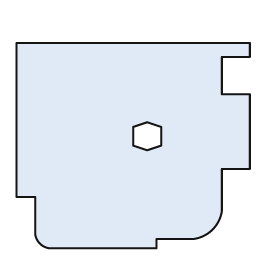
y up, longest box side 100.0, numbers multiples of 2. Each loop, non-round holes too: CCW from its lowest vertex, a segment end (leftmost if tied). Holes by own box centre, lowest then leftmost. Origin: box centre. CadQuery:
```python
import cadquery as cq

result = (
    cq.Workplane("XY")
    .moveTo(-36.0, -44.0)
    .lineTo(10.0, -44.0)
    .lineTo(10.0, -40.0)
    .lineTo(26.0, -40.0)
    .threePointArc((34.0, -36.0), (38.0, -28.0))
    .lineTo(38.0, -10.0)
    .lineTo(50.0, -10.0)
    .lineTo(50.0, 22.0)
    .lineTo(38.0, 22.0)
    .lineTo(38.0, 38.0)
    .lineTo(50.0, 38.0)
    .lineTo(50.0, 44.0)
    .lineTo(-50.0, 44.0)
    .lineTo(-50.0, -22.0)
    .lineTo(-42.0, -22.0)
    .lineTo(-42.0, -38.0)
    .threePointArc((-40.0, -42.0), (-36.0, -44.0))
    .close()
    .moveTo(6.0, -2.0)
    .lineTo(12.0, 0.0)
    .lineTo(12.0, 8.0)
    .lineTo(6.0, 10.0)
    .lineTo(0.0, 8.0)
    .lineTo(0.0, 0.0)
    .close()
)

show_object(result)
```